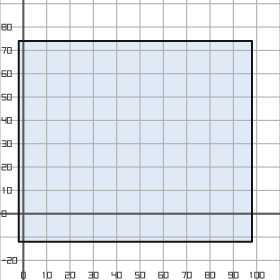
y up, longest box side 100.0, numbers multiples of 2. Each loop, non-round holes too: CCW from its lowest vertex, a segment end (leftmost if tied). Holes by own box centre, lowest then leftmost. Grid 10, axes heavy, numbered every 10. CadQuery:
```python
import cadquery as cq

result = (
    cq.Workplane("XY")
    .moveTo(-2.0, -12.0)
    .lineTo(98.0, -12.0)
    .lineTo(98.0, 74.0)
    .lineTo(-2.0, 74.0)
    .close()
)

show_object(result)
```